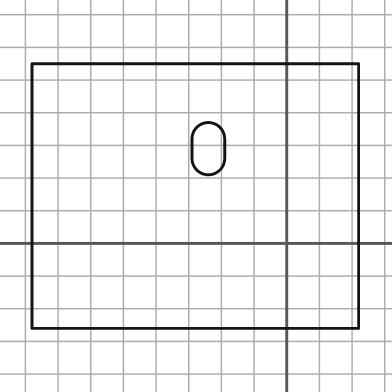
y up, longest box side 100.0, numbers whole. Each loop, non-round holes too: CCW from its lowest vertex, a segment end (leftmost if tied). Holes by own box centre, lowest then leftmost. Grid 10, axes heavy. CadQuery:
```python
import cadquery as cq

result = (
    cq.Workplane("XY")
    .moveTo(-78.0, -26.0)
    .lineTo(22.0, -26.0)
    .lineTo(22.0, 55.0)
    .lineTo(-78.0, 55.0)
    .close()
    .moveTo(-29.0, 26.0)
    .threePointArc((-24.0, 21.0), (-19.0, 26.0))
    .lineTo(-19.0, 32.0)
    .threePointArc((-24.0, 37.0), (-29.0, 32.0))
    .close()
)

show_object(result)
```